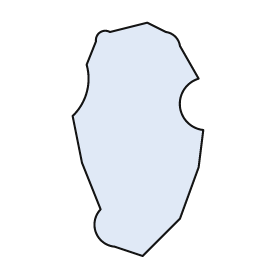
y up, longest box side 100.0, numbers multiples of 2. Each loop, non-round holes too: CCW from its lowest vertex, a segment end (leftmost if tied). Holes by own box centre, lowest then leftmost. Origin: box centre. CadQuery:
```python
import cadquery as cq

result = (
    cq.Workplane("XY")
    .moveTo(2.0, -50.0)
    .lineTo(18.0, -34.0)
    .lineTo(26.0, -12.0)
    .lineTo(28.0, 4.0)
    .threePointArc((18.0, 14.0), (26.0, 26.0))
    .lineTo(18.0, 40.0)
    .threePointArc((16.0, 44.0), (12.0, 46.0))
    .lineTo(4.0, 50.0)
    .lineTo(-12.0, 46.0)
    .threePointArc((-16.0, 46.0), (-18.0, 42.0))
    .lineTo(-22.0, 32.0)
    .threePointArc((-22.0, 20.0), (-28.0, 10.0))
    .lineTo(-24.0, -10.0)
    .lineTo(-16.0, -30.0)
    .threePointArc((-18.0, -40.0), (-10.0, -46.0))
    .close()
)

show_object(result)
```